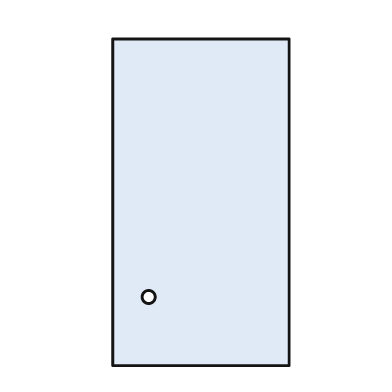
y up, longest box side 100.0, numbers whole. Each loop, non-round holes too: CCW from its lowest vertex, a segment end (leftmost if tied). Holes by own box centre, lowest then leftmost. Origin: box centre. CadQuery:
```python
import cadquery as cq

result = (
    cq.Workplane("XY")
    .moveTo(-27.0, -50.0)
    .lineTo(27.0, -50.0)
    .lineTo(27.0, 50.0)
    .lineTo(-27.0, 50.0)
    .close()
    .moveTo(-16.0, -29.0)
    .circle(2.0)
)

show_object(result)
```